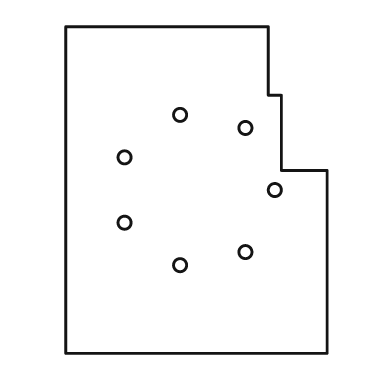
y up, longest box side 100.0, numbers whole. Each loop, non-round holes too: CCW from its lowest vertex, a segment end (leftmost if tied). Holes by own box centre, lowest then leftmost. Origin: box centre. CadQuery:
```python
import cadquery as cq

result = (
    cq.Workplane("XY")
    .moveTo(-40.0, -50.0)
    .lineTo(40.0, -50.0)
    .lineTo(40.0, 6.0)
    .lineTo(26.0, 6.0)
    .lineTo(26.0, 29.0)
    .lineTo(22.0, 29.0)
    .lineTo(22.0, 50.0)
    .lineTo(-40.0, 50.0)
    .close()
    .moveTo(-5.0, -23.0)
    .circle(2.0)
    .moveTo(15.0, -19.0)
    .circle(2.0)
    .moveTo(-22.0, -10.0)
    .circle(2.0)
    .moveTo(24.0, 0.0)
    .circle(2.0)
    .moveTo(-22.0, 10.0)
    .circle(2.0)
    .moveTo(15.0, 19.0)
    .circle(2.0)
    .moveTo(-5.0, 23.0)
    .circle(2.0)
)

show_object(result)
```